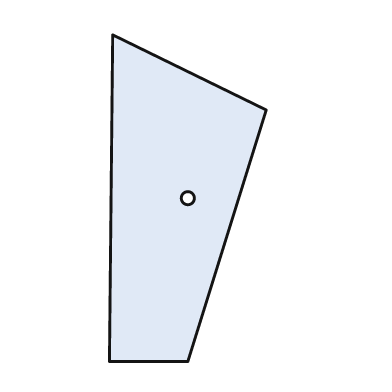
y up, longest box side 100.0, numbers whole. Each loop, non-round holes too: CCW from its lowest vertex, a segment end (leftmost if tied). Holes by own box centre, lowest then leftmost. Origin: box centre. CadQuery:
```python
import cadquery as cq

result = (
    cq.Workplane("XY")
    .moveTo(-24.0, -50.0)
    .lineTo(0.0, -50.0)
    .lineTo(24.0, 27.0)
    .lineTo(-23.0, 50.0)
    .close()
    .moveTo(0.0, 0.0)
    .circle(2.0)
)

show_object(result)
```